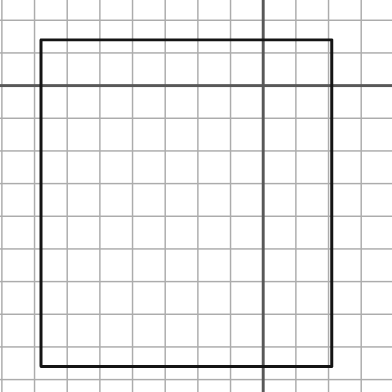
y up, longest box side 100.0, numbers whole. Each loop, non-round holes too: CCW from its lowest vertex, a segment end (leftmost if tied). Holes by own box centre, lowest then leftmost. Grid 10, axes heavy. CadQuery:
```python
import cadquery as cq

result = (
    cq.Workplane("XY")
    .moveTo(-68.0, -86.0)
    .lineTo(21.0, -86.0)
    .lineTo(21.0, 14.0)
    .lineTo(-68.0, 14.0)
    .close()
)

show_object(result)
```